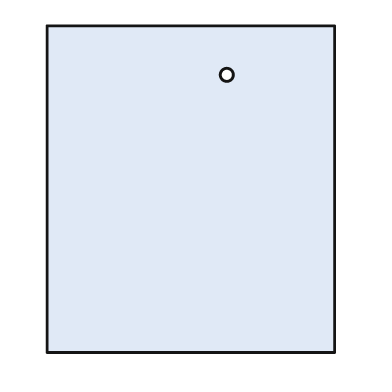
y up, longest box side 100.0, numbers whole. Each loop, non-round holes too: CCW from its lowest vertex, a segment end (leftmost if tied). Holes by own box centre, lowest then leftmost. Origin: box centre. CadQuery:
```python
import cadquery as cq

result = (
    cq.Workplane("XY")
    .moveTo(-44.0, -50.0)
    .lineTo(44.0, -50.0)
    .lineTo(44.0, 50.0)
    .lineTo(-44.0, 50.0)
    .close()
    .moveTo(11.0, 35.0)
    .circle(2.0)
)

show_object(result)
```